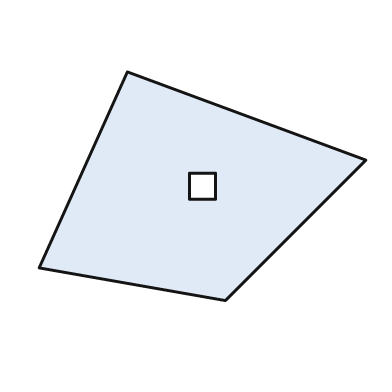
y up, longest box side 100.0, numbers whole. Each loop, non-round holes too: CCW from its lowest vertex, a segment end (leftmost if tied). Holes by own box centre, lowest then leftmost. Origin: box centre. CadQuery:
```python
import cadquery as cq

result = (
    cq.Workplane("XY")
    .moveTo(7.0, -35.0)
    .lineTo(50.0, 8.0)
    .lineTo(-23.0, 35.0)
    .lineTo(-50.0, -25.0)
    .close()
    .moveTo(-4.0, -4.0)
    .lineTo(4.0, -4.0)
    .lineTo(4.0, 4.0)
    .lineTo(-4.0, 4.0)
    .close()
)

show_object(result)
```